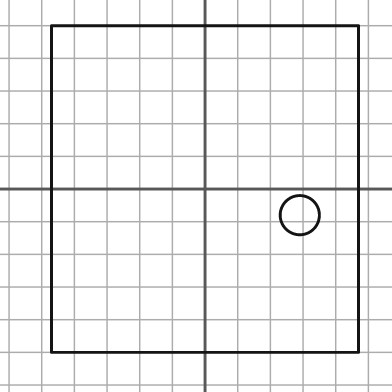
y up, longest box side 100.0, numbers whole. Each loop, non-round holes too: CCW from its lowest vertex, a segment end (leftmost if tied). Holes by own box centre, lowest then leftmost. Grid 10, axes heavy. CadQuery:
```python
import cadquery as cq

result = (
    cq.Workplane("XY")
    .moveTo(-47.0, -50.0)
    .lineTo(47.0, -50.0)
    .lineTo(47.0, 50.0)
    .lineTo(-47.0, 50.0)
    .close()
    .moveTo(29.0, -8.0)
    .circle(6.0)
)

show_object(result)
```